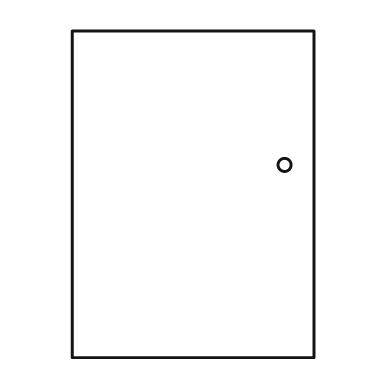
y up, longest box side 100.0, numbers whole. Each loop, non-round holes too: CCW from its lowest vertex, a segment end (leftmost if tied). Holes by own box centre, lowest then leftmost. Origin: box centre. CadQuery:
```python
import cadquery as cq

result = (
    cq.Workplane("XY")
    .moveTo(-37.0, -50.0)
    .lineTo(37.0, -50.0)
    .lineTo(37.0, 50.0)
    .lineTo(-37.0, 50.0)
    .close()
    .moveTo(28.0, 9.0)
    .circle(2.0)
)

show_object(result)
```